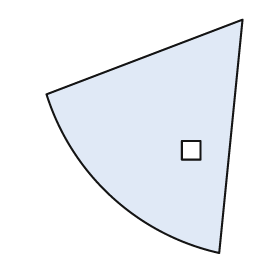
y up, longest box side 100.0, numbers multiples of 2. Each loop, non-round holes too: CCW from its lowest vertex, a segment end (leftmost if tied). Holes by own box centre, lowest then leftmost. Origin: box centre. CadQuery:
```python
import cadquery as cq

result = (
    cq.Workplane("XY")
    .moveTo(32.0, -50.0)
    .lineTo(42.0, 50.0)
    .lineTo(-42.0, 18.0)
    .threePointArc((-14.0, -26.0), (32.0, -50.0))
    .close()
    .moveTo(16.0, -10.0)
    .lineTo(24.0, -10.0)
    .lineTo(24.0, -2.0)
    .lineTo(16.0, -2.0)
    .close()
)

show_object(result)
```